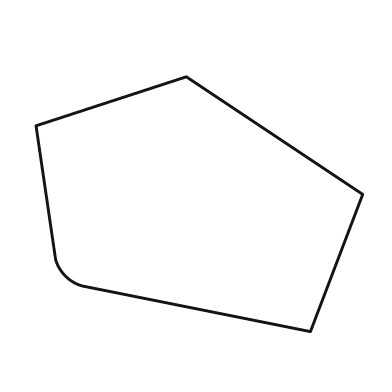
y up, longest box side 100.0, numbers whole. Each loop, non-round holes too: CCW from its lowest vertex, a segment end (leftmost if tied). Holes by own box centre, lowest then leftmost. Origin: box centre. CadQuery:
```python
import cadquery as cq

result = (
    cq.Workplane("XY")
    .moveTo(34.0, -39.0)
    .lineTo(50.0, 3.0)
    .lineTo(-4.0, 39.0)
    .lineTo(-50.0, 24.0)
    .lineTo(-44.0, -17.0)
    .threePointArc((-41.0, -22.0), (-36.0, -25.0))
    .close()
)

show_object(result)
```